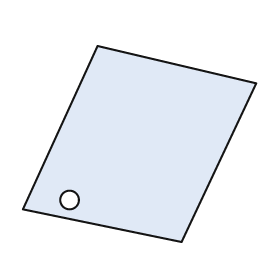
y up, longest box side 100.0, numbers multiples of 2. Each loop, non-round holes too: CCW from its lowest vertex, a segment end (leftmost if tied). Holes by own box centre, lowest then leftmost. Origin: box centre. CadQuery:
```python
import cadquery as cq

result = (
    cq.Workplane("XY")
    .moveTo(18.0, -42.0)
    .lineTo(50.0, 26.0)
    .lineTo(-18.0, 42.0)
    .lineTo(-50.0, -28.0)
    .close()
    .moveTo(-30.0, -24.0)
    .circle(4.0)
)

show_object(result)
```